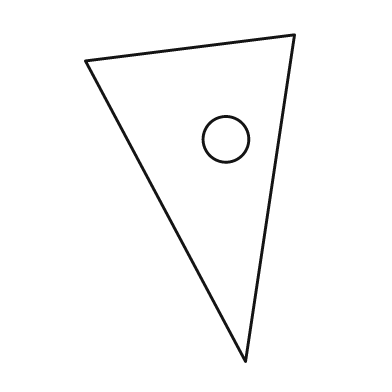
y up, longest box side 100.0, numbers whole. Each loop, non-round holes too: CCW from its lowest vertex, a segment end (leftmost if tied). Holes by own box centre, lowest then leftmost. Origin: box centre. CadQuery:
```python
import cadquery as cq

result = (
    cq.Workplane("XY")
    .moveTo(17.0, -50.0)
    .lineTo(32.0, 50.0)
    .lineTo(-32.0, 42.0)
    .close()
    .moveTo(11.0, 18.0)
    .circle(7.0)
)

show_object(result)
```